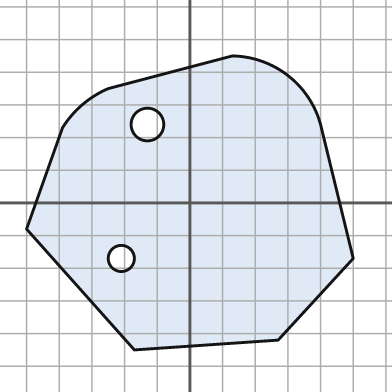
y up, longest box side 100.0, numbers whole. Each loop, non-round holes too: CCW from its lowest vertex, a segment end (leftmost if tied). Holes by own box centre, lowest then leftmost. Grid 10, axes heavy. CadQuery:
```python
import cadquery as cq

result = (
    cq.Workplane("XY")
    .moveTo(-17.0, -45.0)
    .lineTo(27.0, -42.0)
    .lineTo(50.0, -17.0)
    .lineTo(40.0, 24.0)
    .threePointArc((30.0, 39.0), (13.0, 45.0))
    .lineTo(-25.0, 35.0)
    .threePointArc((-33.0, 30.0), (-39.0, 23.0))
    .lineTo(-50.0, -8.0)
    .close()
    .moveTo(-21.0, -17.0)
    .circle(4.0)
    .moveTo(-13.0, 24.0)
    .circle(5.0)
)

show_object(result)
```